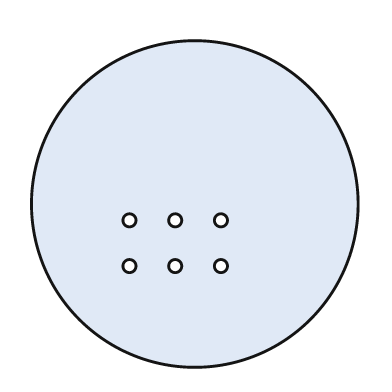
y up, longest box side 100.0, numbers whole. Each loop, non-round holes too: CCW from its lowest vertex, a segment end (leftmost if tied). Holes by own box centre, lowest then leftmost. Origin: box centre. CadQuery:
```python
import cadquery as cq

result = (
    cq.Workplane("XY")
    .moveTo(0.0, 0.0)
    .circle(50.0)
    .moveTo(-20.0, -19.0)
    .circle(2.0)
    .moveTo(-6.0, -19.0)
    .circle(2.0)
    .moveTo(8.0, -19.0)
    .circle(2.0)
    .moveTo(-20.0, -5.0)
    .circle(2.0)
    .moveTo(-6.0, -5.0)
    .circle(2.0)
    .moveTo(8.0, -5.0)
    .circle(2.0)
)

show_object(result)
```